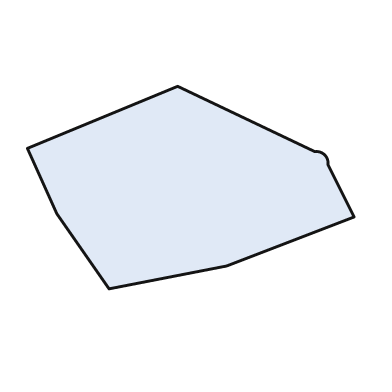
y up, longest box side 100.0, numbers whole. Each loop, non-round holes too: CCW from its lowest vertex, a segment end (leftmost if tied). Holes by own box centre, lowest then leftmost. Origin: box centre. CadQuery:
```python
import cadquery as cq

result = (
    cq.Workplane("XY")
    .moveTo(-25.0, -31.0)
    .lineTo(11.0, -24.0)
    .lineTo(50.0, -9.0)
    .lineTo(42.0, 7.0)
    .threePointArc((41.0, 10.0), (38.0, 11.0))
    .lineTo(-4.0, 31.0)
    .lineTo(-50.0, 12.0)
    .lineTo(-41.0, -8.0)
    .close()
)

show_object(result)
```